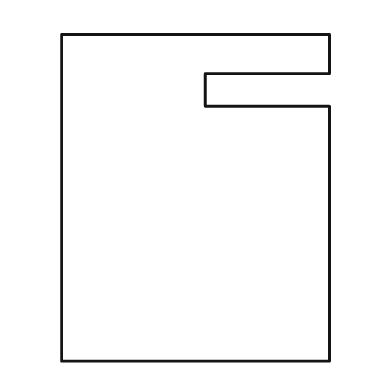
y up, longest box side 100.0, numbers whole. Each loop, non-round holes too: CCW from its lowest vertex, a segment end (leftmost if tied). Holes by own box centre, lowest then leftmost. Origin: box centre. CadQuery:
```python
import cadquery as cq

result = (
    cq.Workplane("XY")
    .moveTo(-41.0, -50.0)
    .lineTo(41.0, -50.0)
    .lineTo(41.0, 28.0)
    .lineTo(3.0, 28.0)
    .lineTo(3.0, 38.0)
    .lineTo(41.0, 38.0)
    .lineTo(41.0, 50.0)
    .lineTo(-41.0, 50.0)
    .close()
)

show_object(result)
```